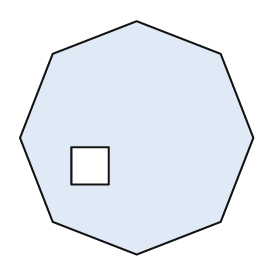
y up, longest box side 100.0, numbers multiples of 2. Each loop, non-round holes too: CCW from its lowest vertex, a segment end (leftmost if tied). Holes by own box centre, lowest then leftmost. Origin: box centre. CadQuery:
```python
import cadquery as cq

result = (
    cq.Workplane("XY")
    .moveTo(0.0, -50.0)
    .lineTo(36.0, -36.0)
    .lineTo(50.0, 0.0)
    .lineTo(36.0, 36.0)
    .lineTo(0.0, 50.0)
    .lineTo(-36.0, 36.0)
    .lineTo(-50.0, 0.0)
    .lineTo(-36.0, -36.0)
    .close()
    .moveTo(-28.0, -20.0)
    .lineTo(-12.0, -20.0)
    .lineTo(-12.0, -4.0)
    .lineTo(-28.0, -4.0)
    .close()
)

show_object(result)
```